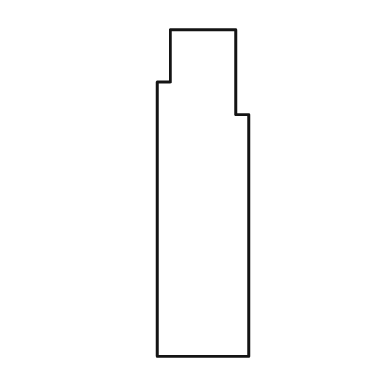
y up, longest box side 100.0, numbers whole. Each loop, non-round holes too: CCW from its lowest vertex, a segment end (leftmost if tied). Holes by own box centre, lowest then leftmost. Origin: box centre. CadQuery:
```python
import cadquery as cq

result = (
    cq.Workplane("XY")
    .moveTo(-14.0, -50.0)
    .lineTo(14.0, -50.0)
    .lineTo(14.0, 24.0)
    .lineTo(10.0, 24.0)
    .lineTo(10.0, 50.0)
    .lineTo(-10.0, 50.0)
    .lineTo(-10.0, 34.0)
    .lineTo(-14.0, 34.0)
    .close()
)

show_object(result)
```